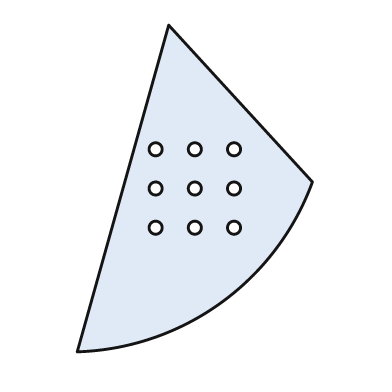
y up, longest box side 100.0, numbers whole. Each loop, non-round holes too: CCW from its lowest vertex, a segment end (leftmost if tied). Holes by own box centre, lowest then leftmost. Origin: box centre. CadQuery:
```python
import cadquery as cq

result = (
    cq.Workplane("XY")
    .moveTo(-36.0, -50.0)
    .threePointArc((8.0, -35.0), (36.0, 2.0))
    .lineTo(-8.0, 50.0)
    .close()
    .moveTo(-12.0, -12.0)
    .circle(2.0)
    .moveTo(0.0, -12.0)
    .circle(2.0)
    .moveTo(12.0, -12.0)
    .circle(2.0)
    .moveTo(-12.0, 0.0)
    .circle(2.0)
    .moveTo(0.0, 0.0)
    .circle(2.0)
    .moveTo(12.0, 0.0)
    .circle(2.0)
    .moveTo(-12.0, 12.0)
    .circle(2.0)
    .moveTo(0.0, 12.0)
    .circle(2.0)
    .moveTo(12.0, 12.0)
    .circle(2.0)
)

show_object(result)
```